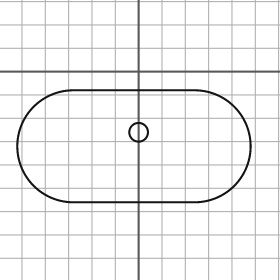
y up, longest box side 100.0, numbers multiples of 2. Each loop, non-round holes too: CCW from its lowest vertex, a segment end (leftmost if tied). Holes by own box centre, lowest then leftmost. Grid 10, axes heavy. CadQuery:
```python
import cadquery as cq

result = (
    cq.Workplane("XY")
    .moveTo(-28.0, -56.0)
    .lineTo(24.0, -56.0)
    .threePointArc((48.0, -32.0), (24.0, -8.0))
    .lineTo(-28.0, -8.0)
    .threePointArc((-52.0, -32.0), (-28.0, -56.0))
    .close()
    .moveTo(0.0, -26.0)
    .circle(4.0)
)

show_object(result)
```